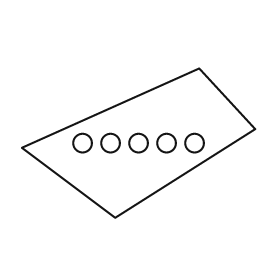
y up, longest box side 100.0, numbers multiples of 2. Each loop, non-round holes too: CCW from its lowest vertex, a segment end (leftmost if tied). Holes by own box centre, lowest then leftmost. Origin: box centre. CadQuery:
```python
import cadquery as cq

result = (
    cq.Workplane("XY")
    .moveTo(-10.0, -32.0)
    .lineTo(50.0, 6.0)
    .lineTo(26.0, 32.0)
    .lineTo(-50.0, -2.0)
    .close()
    .moveTo(-24.0, 0.0)
    .circle(4.0)
    .moveTo(-12.0, 0.0)
    .circle(4.0)
    .moveTo(0.0, 0.0)
    .circle(4.0)
    .moveTo(12.0, 0.0)
    .circle(4.0)
    .moveTo(24.0, 0.0)
    .circle(4.0)
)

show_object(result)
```